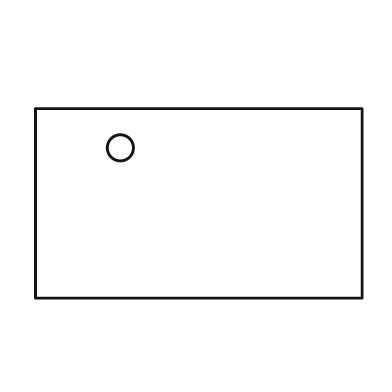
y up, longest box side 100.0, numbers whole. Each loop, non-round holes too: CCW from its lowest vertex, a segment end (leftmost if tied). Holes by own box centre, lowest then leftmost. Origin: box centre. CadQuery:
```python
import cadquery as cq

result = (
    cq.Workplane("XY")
    .moveTo(-50.0, -29.0)
    .lineTo(50.0, -29.0)
    .lineTo(50.0, 29.0)
    .lineTo(-50.0, 29.0)
    .close()
    .moveTo(-24.0, 17.0)
    .circle(4.0)
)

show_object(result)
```